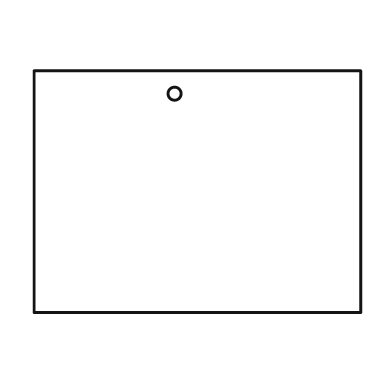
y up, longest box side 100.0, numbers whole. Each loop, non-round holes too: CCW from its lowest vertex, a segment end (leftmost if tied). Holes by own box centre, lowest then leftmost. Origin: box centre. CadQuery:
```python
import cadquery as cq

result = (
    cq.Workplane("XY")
    .moveTo(-50.0, -37.0)
    .lineTo(50.0, -37.0)
    .lineTo(50.0, 37.0)
    .lineTo(-50.0, 37.0)
    .close()
    .moveTo(-7.0, 30.0)
    .circle(2.0)
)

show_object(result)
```